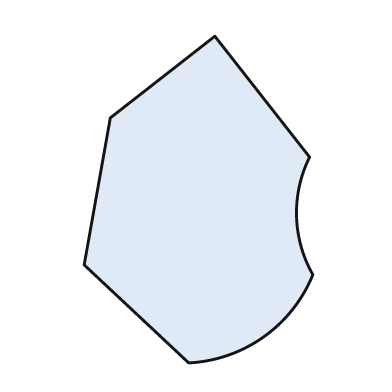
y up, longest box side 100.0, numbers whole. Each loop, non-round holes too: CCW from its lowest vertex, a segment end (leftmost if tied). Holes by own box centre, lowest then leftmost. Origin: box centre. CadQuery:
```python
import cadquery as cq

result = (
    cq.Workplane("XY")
    .moveTo(-3.0, -50.0)
    .threePointArc((20.0, -42.0), (35.0, -23.0))
    .threePointArc((30.0, -5.0), (34.0, 13.0))
    .lineTo(5.0, 50.0)
    .lineTo(-27.0, 25.0)
    .lineTo(-35.0, -20.0)
    .close()
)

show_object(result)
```